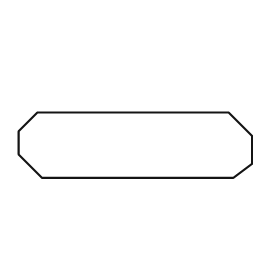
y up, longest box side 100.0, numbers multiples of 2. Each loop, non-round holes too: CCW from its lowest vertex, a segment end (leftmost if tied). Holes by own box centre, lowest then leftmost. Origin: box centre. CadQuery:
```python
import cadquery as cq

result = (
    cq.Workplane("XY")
    .moveTo(-40.0, -14.0)
    .lineTo(42.0, -14.0)
    .lineTo(50.0, -8.0)
    .lineTo(50.0, 4.0)
    .lineTo(40.0, 14.0)
    .lineTo(-42.0, 14.0)
    .lineTo(-50.0, 6.0)
    .lineTo(-50.0, -4.0)
    .close()
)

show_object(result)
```